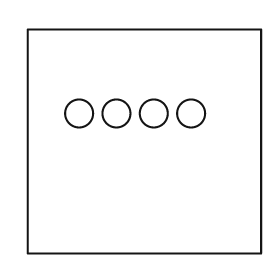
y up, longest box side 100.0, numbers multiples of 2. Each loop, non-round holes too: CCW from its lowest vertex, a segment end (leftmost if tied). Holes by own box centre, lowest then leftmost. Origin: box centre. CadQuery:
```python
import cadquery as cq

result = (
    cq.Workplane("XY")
    .moveTo(-50.0, -48.0)
    .lineTo(50.0, -48.0)
    .lineTo(50.0, 48.0)
    .lineTo(-50.0, 48.0)
    .close()
    .moveTo(-28.0, 12.0)
    .circle(6.0)
    .moveTo(-12.0, 12.0)
    .circle(6.0)
    .moveTo(4.0, 12.0)
    .circle(6.0)
    .moveTo(20.0, 12.0)
    .circle(6.0)
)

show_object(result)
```